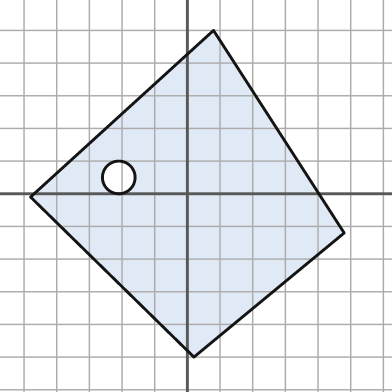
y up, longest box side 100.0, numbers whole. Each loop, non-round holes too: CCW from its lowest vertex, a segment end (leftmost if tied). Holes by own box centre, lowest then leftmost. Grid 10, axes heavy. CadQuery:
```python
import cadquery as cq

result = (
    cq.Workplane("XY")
    .moveTo(2.0, -50.0)
    .lineTo(48.0, -12.0)
    .lineTo(8.0, 50.0)
    .lineTo(-48.0, -1.0)
    .close()
    .moveTo(-21.0, 5.0)
    .circle(5.0)
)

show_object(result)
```